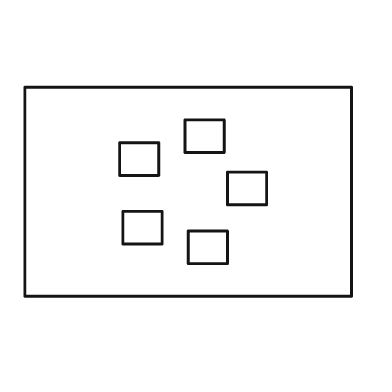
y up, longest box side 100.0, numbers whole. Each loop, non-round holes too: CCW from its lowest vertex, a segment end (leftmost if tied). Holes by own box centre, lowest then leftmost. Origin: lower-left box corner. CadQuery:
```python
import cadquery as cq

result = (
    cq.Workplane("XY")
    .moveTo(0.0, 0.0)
    .lineTo(100.0, 0.0)
    .lineTo(100.0, 64.0)
    .lineTo(0.0, 64.0)
    .close()
    .moveTo(50.0, 10.0)
    .lineTo(62.0, 10.0)
    .lineTo(62.0, 20.0)
    .lineTo(50.0, 20.0)
    .close()
    .moveTo(30.0, 16.0)
    .lineTo(42.0, 16.0)
    .lineTo(42.0, 26.0)
    .lineTo(30.0, 26.0)
    .close()
    .moveTo(62.0, 28.0)
    .lineTo(74.0, 28.0)
    .lineTo(74.0, 38.0)
    .lineTo(62.0, 38.0)
    .close()
    .moveTo(29.0, 37.0)
    .lineTo(41.0, 37.0)
    .lineTo(41.0, 47.0)
    .lineTo(29.0, 47.0)
    .close()
    .moveTo(49.0, 44.0)
    .lineTo(61.0, 44.0)
    .lineTo(61.0, 54.0)
    .lineTo(49.0, 54.0)
    .close()
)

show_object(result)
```